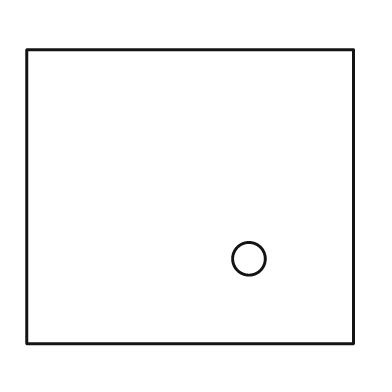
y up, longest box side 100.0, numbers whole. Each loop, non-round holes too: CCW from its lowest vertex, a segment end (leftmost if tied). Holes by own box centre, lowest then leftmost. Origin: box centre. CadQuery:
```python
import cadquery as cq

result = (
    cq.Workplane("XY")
    .moveTo(-50.0, -45.0)
    .lineTo(50.0, -45.0)
    .lineTo(50.0, 45.0)
    .lineTo(-50.0, 45.0)
    .close()
    .moveTo(18.0, -19.0)
    .circle(5.0)
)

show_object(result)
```